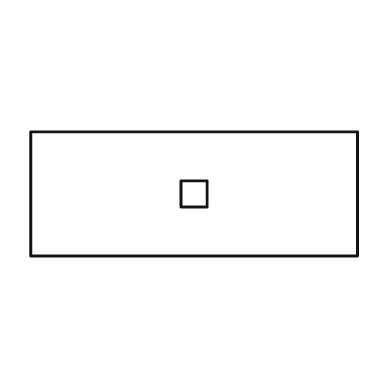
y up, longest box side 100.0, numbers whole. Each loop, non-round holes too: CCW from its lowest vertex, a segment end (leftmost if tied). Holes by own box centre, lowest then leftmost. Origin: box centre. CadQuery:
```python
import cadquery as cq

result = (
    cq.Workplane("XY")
    .moveTo(-50.0, -19.0)
    .lineTo(50.0, -19.0)
    .lineTo(50.0, 19.0)
    .lineTo(-50.0, 19.0)
    .close()
    .moveTo(-4.0, -4.0)
    .lineTo(4.0, -4.0)
    .lineTo(4.0, 4.0)
    .lineTo(-4.0, 4.0)
    .close()
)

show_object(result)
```